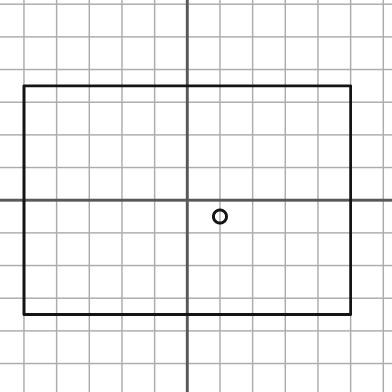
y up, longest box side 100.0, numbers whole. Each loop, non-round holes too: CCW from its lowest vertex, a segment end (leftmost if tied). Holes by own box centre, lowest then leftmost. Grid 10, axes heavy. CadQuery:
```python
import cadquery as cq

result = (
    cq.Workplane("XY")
    .moveTo(-50.0, -35.0)
    .lineTo(50.0, -35.0)
    .lineTo(50.0, 35.0)
    .lineTo(-50.0, 35.0)
    .close()
    .moveTo(10.0, -5.0)
    .circle(2.0)
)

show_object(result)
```